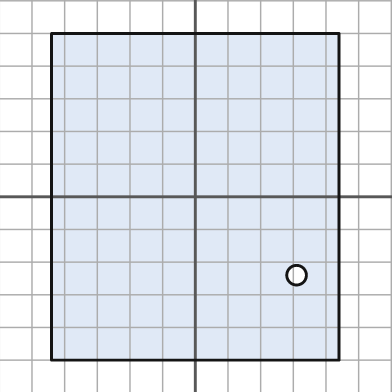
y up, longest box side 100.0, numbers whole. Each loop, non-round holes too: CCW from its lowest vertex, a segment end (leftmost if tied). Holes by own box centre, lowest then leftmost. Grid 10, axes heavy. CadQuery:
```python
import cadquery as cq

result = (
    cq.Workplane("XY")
    .moveTo(-44.0, -50.0)
    .lineTo(44.0, -50.0)
    .lineTo(44.0, 50.0)
    .lineTo(-44.0, 50.0)
    .close()
    .moveTo(31.0, -24.0)
    .circle(3.0)
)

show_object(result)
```